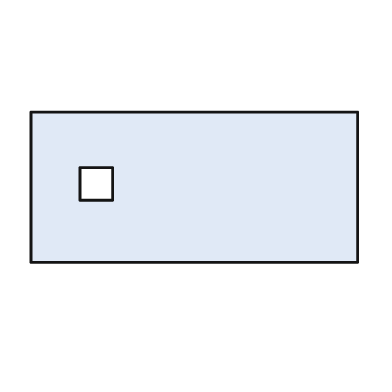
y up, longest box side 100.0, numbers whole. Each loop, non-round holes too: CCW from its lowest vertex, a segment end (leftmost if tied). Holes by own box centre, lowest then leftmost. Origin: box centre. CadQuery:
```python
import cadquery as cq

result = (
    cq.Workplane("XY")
    .moveTo(-50.0, -23.0)
    .lineTo(50.0, -23.0)
    .lineTo(50.0, 23.0)
    .lineTo(-50.0, 23.0)
    .close()
    .moveTo(-35.0, -4.0)
    .lineTo(-25.0, -4.0)
    .lineTo(-25.0, 6.0)
    .lineTo(-35.0, 6.0)
    .close()
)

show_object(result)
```